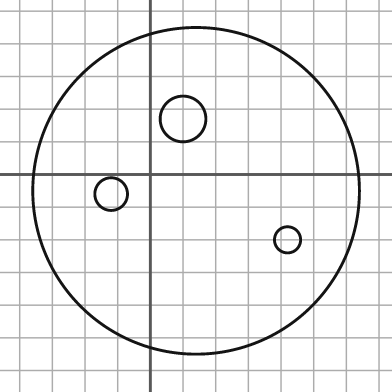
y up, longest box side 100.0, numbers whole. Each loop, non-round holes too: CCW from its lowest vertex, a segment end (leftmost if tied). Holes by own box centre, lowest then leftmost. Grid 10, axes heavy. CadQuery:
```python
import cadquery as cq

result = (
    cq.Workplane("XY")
    .moveTo(14.0, -5.0)
    .circle(50.0)
    .moveTo(42.0, -20.0)
    .circle(4.0)
    .moveTo(-12.0, -6.0)
    .circle(5.0)
    .moveTo(10.0, 17.0)
    .circle(7.0)
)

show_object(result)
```